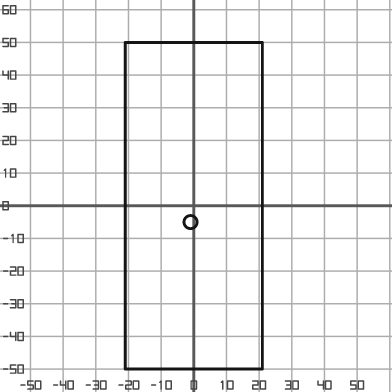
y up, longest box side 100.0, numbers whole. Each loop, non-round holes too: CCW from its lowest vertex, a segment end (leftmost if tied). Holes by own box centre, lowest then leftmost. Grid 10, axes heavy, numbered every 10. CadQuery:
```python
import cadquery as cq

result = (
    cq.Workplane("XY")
    .moveTo(-21.0, -50.0)
    .lineTo(21.0, -50.0)
    .lineTo(21.0, 50.0)
    .lineTo(-21.0, 50.0)
    .close()
    .moveTo(-1.0, -5.0)
    .circle(2.0)
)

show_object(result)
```